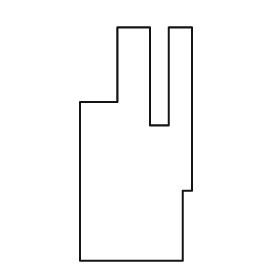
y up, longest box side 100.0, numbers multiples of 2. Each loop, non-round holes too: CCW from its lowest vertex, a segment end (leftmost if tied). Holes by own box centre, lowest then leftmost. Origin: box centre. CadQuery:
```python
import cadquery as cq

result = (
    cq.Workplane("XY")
    .moveTo(-24.0, -50.0)
    .lineTo(20.0, -50.0)
    .lineTo(20.0, -20.0)
    .lineTo(24.0, -20.0)
    .lineTo(24.0, 50.0)
    .lineTo(14.0, 50.0)
    .lineTo(14.0, 8.0)
    .lineTo(6.0, 8.0)
    .lineTo(6.0, 50.0)
    .lineTo(-8.0, 50.0)
    .lineTo(-8.0, 18.0)
    .lineTo(-24.0, 18.0)
    .close()
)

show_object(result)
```